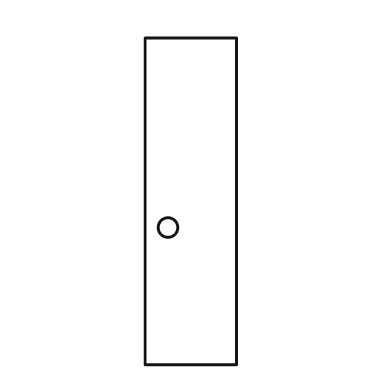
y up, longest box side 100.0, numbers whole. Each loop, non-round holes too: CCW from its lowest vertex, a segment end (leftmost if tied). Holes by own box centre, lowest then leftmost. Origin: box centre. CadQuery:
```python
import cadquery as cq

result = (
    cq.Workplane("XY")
    .moveTo(-14.0, -50.0)
    .lineTo(14.0, -50.0)
    .lineTo(14.0, 50.0)
    .lineTo(-14.0, 50.0)
    .close()
    .moveTo(-7.0, -8.0)
    .circle(3.0)
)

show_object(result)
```